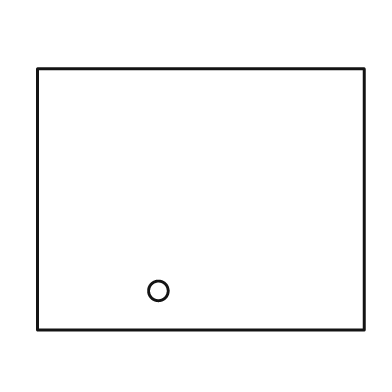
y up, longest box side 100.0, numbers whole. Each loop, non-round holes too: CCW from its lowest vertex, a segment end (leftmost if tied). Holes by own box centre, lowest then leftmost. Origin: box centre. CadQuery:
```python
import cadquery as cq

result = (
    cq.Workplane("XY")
    .moveTo(-50.0, -40.0)
    .lineTo(50.0, -40.0)
    .lineTo(50.0, 40.0)
    .lineTo(-50.0, 40.0)
    .close()
    .moveTo(-13.0, -28.0)
    .circle(3.0)
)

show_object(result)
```